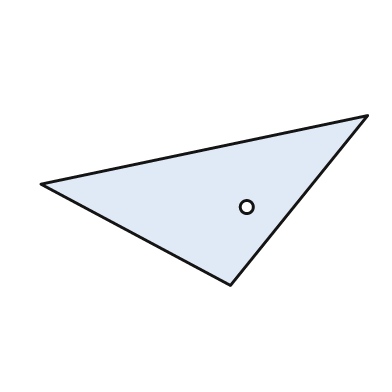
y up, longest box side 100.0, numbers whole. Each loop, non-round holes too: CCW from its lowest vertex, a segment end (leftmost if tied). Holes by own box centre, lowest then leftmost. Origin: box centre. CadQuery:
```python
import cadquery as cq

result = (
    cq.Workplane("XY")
    .moveTo(8.0, -26.0)
    .lineTo(50.0, 26.0)
    .lineTo(-50.0, 5.0)
    .close()
    .moveTo(13.0, -2.0)
    .circle(2.0)
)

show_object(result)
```